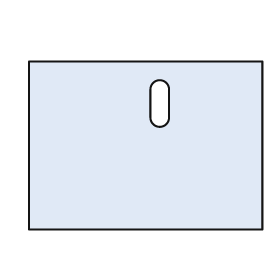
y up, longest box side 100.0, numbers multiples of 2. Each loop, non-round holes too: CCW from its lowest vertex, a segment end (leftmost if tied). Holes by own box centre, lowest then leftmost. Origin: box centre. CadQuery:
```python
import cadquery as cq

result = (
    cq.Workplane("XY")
    .moveTo(-50.0, -36.0)
    .lineTo(50.0, -36.0)
    .lineTo(50.0, 36.0)
    .lineTo(-50.0, 36.0)
    .close()
    .moveTo(2.0, 12.0)
    .threePointArc((6.0, 8.0), (10.0, 12.0))
    .lineTo(10.0, 24.0)
    .threePointArc((6.0, 28.0), (2.0, 24.0))
    .close()
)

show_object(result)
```